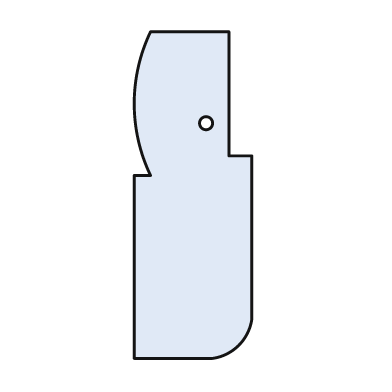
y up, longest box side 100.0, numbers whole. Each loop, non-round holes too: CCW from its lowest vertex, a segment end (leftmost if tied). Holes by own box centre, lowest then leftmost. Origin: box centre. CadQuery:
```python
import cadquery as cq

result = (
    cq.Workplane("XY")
    .moveTo(-18.0, -50.0)
    .lineTo(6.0, -50.0)
    .threePointArc((14.0, -46.0), (18.0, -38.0))
    .lineTo(18.0, 12.0)
    .lineTo(11.0, 12.0)
    .lineTo(11.0, 50.0)
    .lineTo(-13.0, 50.0)
    .threePointArc((-18.0, 28.0), (-13.0, 6.0))
    .lineTo(-18.0, 6.0)
    .close()
    .moveTo(4.0, 22.0)
    .circle(2.0)
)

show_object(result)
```